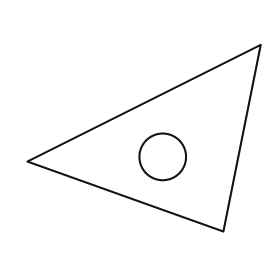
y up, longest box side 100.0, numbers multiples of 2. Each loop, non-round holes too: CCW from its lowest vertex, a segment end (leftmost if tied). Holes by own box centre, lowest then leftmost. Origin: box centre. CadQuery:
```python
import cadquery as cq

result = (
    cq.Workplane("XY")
    .moveTo(34.0, -40.0)
    .lineTo(50.0, 40.0)
    .lineTo(-50.0, -10.0)
    .close()
    .moveTo(8.0, -8.0)
    .circle(10.0)
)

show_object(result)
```